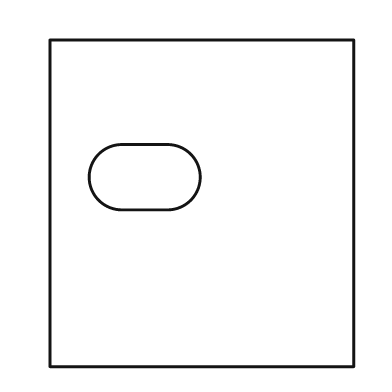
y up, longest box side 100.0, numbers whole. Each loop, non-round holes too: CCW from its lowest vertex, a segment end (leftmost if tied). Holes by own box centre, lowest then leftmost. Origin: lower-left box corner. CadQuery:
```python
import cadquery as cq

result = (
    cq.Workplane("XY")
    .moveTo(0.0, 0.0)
    .lineTo(93.0, 0.0)
    .lineTo(93.0, 100.0)
    .lineTo(0.0, 100.0)
    .close()
    .moveTo(22.0, 48.0)
    .lineTo(36.0, 48.0)
    .threePointArc((46.0, 58.0), (36.0, 68.0))
    .lineTo(22.0, 68.0)
    .threePointArc((12.0, 58.0), (22.0, 48.0))
    .close()
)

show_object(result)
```